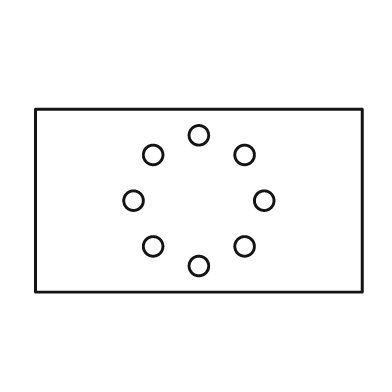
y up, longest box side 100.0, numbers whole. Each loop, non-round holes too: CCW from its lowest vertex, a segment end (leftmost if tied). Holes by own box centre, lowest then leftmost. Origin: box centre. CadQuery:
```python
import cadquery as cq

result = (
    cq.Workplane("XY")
    .moveTo(-50.0, -28.0)
    .lineTo(50.0, -28.0)
    .lineTo(50.0, 28.0)
    .lineTo(-50.0, 28.0)
    .close()
    .moveTo(0.0, -20.0)
    .circle(3.0)
    .moveTo(-14.0, -14.0)
    .circle(3.0)
    .moveTo(14.0, -14.0)
    .circle(3.0)
    .moveTo(-20.0, 0.0)
    .circle(3.0)
    .moveTo(20.0, 0.0)
    .circle(3.0)
    .moveTo(-14.0, 14.0)
    .circle(3.0)
    .moveTo(14.0, 14.0)
    .circle(3.0)
    .moveTo(0.0, 20.0)
    .circle(3.0)
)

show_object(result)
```